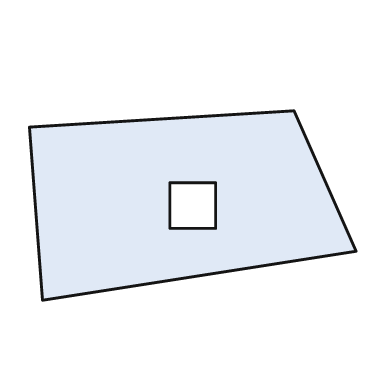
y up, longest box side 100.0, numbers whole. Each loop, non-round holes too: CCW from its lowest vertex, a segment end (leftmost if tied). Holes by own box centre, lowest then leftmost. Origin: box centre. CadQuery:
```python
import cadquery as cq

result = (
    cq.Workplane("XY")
    .moveTo(-46.0, -29.0)
    .lineTo(50.0, -14.0)
    .lineTo(31.0, 29.0)
    .lineTo(-50.0, 24.0)
    .close()
    .moveTo(-7.0, -7.0)
    .lineTo(7.0, -7.0)
    .lineTo(7.0, 7.0)
    .lineTo(-7.0, 7.0)
    .close()
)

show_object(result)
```